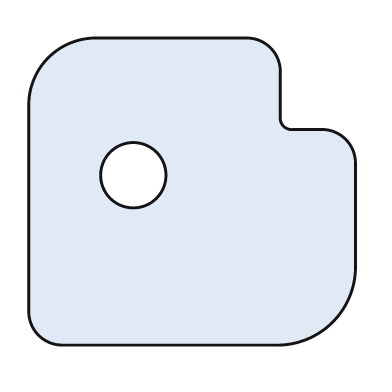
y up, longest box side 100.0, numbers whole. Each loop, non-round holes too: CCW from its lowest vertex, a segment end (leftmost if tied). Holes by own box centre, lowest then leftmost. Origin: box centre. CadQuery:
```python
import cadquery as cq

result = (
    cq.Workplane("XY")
    .moveTo(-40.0, -47.0)
    .lineTo(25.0, -47.0)
    .threePointArc((43.0, -40.0), (50.0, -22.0))
    .lineTo(50.0, 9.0)
    .threePointArc((47.0, 16.0), (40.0, 19.0))
    .lineTo(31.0, 19.0)
    .threePointArc((28.0, 20.0), (27.0, 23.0))
    .lineTo(27.0, 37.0)
    .threePointArc((24.0, 44.0), (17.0, 47.0))
    .lineTo(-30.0, 47.0)
    .threePointArc((-44.0, 41.0), (-50.0, 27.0))
    .lineTo(-50.0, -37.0)
    .threePointArc((-47.0, -44.0), (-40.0, -47.0))
    .close()
    .moveTo(-18.0, 5.0)
    .circle(10.0)
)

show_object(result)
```